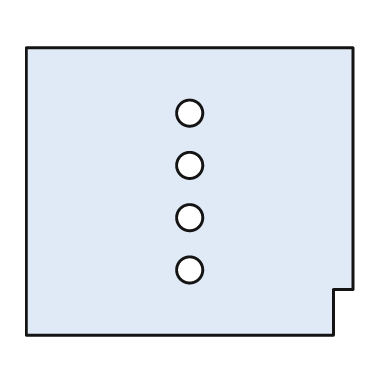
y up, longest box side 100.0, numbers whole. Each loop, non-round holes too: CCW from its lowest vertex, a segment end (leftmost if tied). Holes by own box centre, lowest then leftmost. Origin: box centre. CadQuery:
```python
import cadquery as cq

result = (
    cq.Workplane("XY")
    .moveTo(-50.0, -44.0)
    .lineTo(44.0, -44.0)
    .lineTo(44.0, -30.0)
    .lineTo(50.0, -30.0)
    .lineTo(50.0, 44.0)
    .lineTo(-50.0, 44.0)
    .close()
    .moveTo(0.0, -24.0)
    .circle(4.0)
    .moveTo(0.0, -8.0)
    .circle(4.0)
    .moveTo(0.0, 8.0)
    .circle(4.0)
    .moveTo(0.0, 24.0)
    .circle(4.0)
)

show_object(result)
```